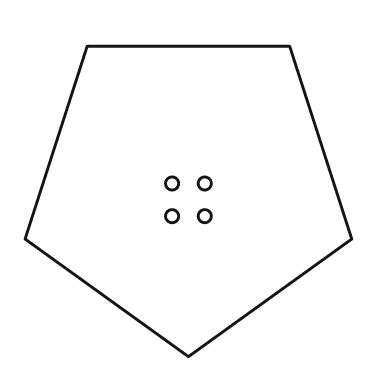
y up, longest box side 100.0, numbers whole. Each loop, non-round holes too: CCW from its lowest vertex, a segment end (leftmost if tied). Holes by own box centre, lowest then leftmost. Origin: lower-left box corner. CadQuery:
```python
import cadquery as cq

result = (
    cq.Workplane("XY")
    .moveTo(50.0, 0.0)
    .lineTo(100.0, 36.0)
    .lineTo(81.0, 95.0)
    .lineTo(19.0, 95.0)
    .lineTo(0.0, 36.0)
    .close()
    .moveTo(45.0, 43.0)
    .circle(2.0)
    .moveTo(55.0, 43.0)
    .circle(2.0)
    .moveTo(45.0, 53.0)
    .circle(2.0)
    .moveTo(55.0, 53.0)
    .circle(2.0)
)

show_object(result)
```